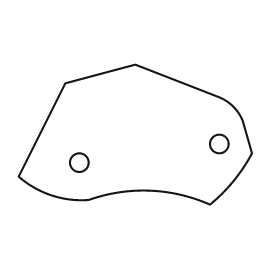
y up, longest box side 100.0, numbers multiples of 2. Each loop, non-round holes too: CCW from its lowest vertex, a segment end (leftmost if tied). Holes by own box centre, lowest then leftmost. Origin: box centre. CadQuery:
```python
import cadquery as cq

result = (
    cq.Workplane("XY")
    .moveTo(32.0, -30.0)
    .threePointArc((42.0, -20.0), (50.0, -8.0))
    .lineTo(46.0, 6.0)
    .threePointArc((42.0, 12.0), (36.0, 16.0))
    .lineTo(0.0, 30.0)
    .lineTo(-30.0, 22.0)
    .lineTo(-50.0, -18.0)
    .threePointArc((-36.0, -26.0), (-20.0, -28.0))
    .threePointArc((6.0, -24.0), (32.0, -30.0))
    .close()
    .moveTo(-24.0, -12.0)
    .circle(4.0)
    .moveTo(36.0, -4.0)
    .circle(4.0)
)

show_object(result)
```